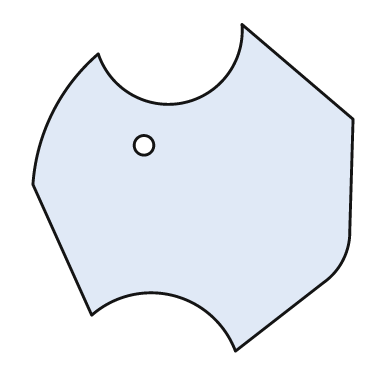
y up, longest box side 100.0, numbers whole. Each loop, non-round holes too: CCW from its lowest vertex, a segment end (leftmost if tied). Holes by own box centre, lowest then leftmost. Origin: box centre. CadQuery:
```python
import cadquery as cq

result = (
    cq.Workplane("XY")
    .moveTo(13.0, -50.0)
    .lineTo(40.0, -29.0)
    .threePointArc((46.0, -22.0), (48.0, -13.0))
    .lineTo(49.0, 21.0)
    .lineTo(15.0, 50.0)
    .threePointArc((-3.0, 26.0), (-29.0, 41.0))
    .threePointArc((-43.0, 23.0), (-49.0, 1.0))
    .lineTo(-31.0, -39.0)
    .threePointArc((-6.0, -33.0), (13.0, -50.0))
    .close()
    .moveTo(-15.0, 13.0)
    .circle(3.0)
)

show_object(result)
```